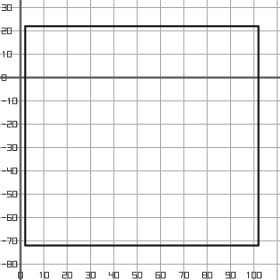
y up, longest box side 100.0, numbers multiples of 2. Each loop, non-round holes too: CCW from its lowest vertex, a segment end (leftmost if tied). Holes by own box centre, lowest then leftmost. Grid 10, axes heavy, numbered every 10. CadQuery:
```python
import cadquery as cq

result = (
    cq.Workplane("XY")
    .moveTo(2.0, -72.0)
    .lineTo(102.0, -72.0)
    .lineTo(102.0, 22.0)
    .lineTo(2.0, 22.0)
    .close()
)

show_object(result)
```